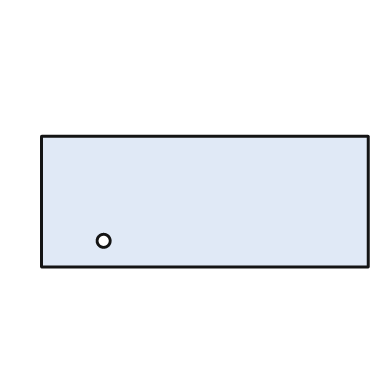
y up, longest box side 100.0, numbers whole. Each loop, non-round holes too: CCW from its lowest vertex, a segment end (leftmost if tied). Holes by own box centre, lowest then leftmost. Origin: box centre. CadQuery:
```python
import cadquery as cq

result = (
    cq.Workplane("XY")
    .moveTo(-50.0, -20.0)
    .lineTo(50.0, -20.0)
    .lineTo(50.0, 20.0)
    .lineTo(-50.0, 20.0)
    .close()
    .moveTo(-31.0, -12.0)
    .circle(2.0)
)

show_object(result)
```